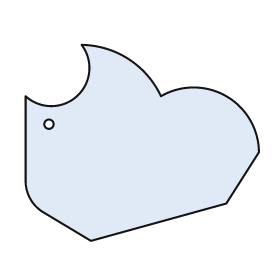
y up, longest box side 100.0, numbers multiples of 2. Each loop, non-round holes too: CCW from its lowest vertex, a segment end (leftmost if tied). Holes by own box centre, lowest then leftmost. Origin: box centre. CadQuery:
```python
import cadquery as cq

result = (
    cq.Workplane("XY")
    .moveTo(-22.0, -42.0)
    .lineTo(36.0, -26.0)
    .lineTo(50.0, -4.0)
    .threePointArc((36.0, 20.0), (8.0, 20.0))
    .threePointArc((-6.0, 36.0), (-26.0, 42.0))
    .threePointArc((-28.0, 20.0), (-50.0, 20.0))
    .lineTo(-50.0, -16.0)
    .threePointArc((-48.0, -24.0), (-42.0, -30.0))
    .close()
    .moveTo(-40.0, 8.0)
    .circle(2.0)
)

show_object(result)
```